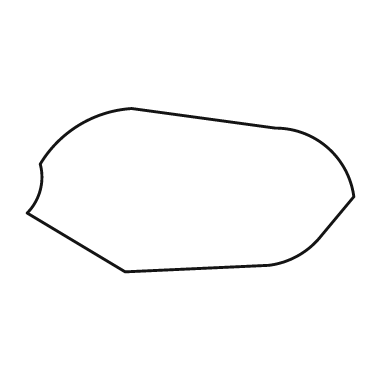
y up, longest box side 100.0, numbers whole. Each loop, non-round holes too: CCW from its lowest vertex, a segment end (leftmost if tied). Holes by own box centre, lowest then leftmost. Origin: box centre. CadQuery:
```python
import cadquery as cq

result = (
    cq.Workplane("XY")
    .moveTo(-20.0, -25.0)
    .lineTo(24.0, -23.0)
    .threePointArc((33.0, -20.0), (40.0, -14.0))
    .lineTo(50.0, -2.0)
    .threePointArc((42.0, 13.0), (26.0, 19.0))
    .lineTo(-18.0, 25.0)
    .threePointArc((-34.0, 20.0), (-46.0, 8.0))
    .threePointArc((-46.0, 0.0), (-50.0, -7.0))
    .close()
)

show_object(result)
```